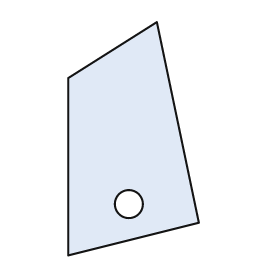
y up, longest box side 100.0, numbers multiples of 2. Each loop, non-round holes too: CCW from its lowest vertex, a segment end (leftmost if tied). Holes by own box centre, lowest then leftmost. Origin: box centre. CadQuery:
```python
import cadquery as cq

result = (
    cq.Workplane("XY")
    .moveTo(-28.0, -50.0)
    .lineTo(28.0, -36.0)
    .lineTo(10.0, 50.0)
    .lineTo(-28.0, 26.0)
    .close()
    .moveTo(-2.0, -28.0)
    .circle(6.0)
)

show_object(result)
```